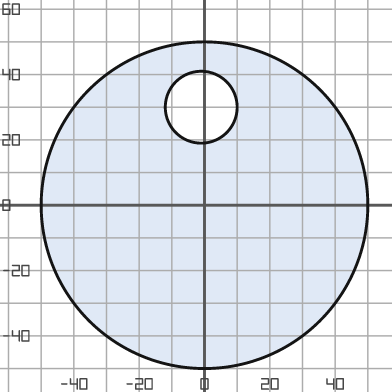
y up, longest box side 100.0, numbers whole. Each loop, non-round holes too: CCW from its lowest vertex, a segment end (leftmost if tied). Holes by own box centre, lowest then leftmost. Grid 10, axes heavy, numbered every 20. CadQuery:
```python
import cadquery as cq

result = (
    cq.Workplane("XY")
    .moveTo(0.0, 0.0)
    .circle(50.0)
    .moveTo(-1.0, 30.0)
    .circle(11.0)
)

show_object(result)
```